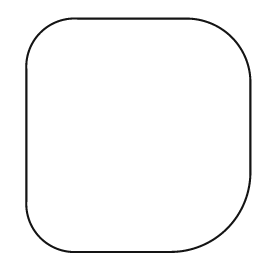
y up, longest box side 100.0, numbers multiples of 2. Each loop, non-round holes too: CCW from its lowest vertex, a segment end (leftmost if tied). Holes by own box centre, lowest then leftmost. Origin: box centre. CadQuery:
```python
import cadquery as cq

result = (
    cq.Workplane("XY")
    .moveTo(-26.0, -50.0)
    .lineTo(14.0, -50.0)
    .threePointArc((38.0, -40.0), (48.0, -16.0))
    .lineTo(48.0, 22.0)
    .threePointArc((40.0, 42.0), (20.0, 50.0))
    .lineTo(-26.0, 50.0)
    .threePointArc((-42.0, 44.0), (-48.0, 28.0))
    .lineTo(-48.0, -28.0)
    .threePointArc((-42.0, -44.0), (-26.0, -50.0))
    .close()
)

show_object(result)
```